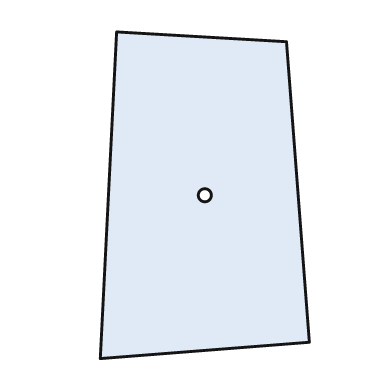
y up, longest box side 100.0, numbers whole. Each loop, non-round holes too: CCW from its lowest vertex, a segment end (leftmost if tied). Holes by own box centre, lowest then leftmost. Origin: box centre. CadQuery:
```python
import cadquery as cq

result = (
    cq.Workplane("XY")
    .moveTo(-32.0, -50.0)
    .lineTo(32.0, -45.0)
    .lineTo(25.0, 47.0)
    .lineTo(-27.0, 50.0)
    .close()
    .moveTo(0.0, 0.0)
    .circle(2.0)
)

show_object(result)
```